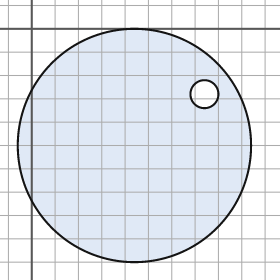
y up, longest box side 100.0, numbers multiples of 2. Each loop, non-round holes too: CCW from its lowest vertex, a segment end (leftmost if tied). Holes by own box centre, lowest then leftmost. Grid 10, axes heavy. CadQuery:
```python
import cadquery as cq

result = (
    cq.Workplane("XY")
    .moveTo(44.0, -50.0)
    .circle(50.0)
    .moveTo(74.0, -28.0)
    .circle(6.0)
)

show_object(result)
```